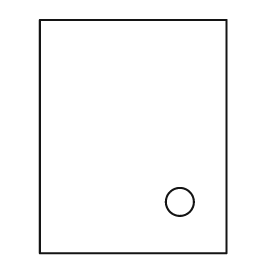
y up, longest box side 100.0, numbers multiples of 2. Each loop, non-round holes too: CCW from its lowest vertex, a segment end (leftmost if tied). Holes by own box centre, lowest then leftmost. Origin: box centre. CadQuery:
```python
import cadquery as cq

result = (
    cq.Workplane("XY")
    .moveTo(-40.0, -50.0)
    .lineTo(40.0, -50.0)
    .lineTo(40.0, 50.0)
    .lineTo(-40.0, 50.0)
    .close()
    .moveTo(20.0, -28.0)
    .circle(6.0)
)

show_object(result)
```